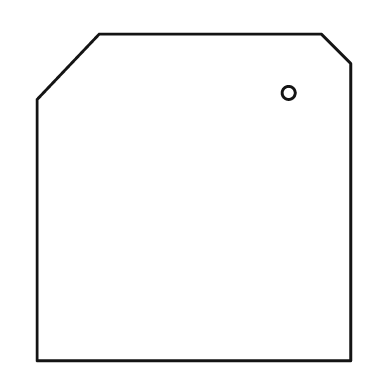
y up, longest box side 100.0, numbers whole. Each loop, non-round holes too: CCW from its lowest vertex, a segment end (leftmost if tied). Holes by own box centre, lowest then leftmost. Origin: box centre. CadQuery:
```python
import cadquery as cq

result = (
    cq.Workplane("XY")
    .moveTo(-48.0, -50.0)
    .lineTo(48.0, -50.0)
    .lineTo(48.0, 41.0)
    .lineTo(39.0, 50.0)
    .lineTo(-29.0, 50.0)
    .lineTo(-48.0, 30.0)
    .close()
    .moveTo(29.0, 32.0)
    .circle(2.0)
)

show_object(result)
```